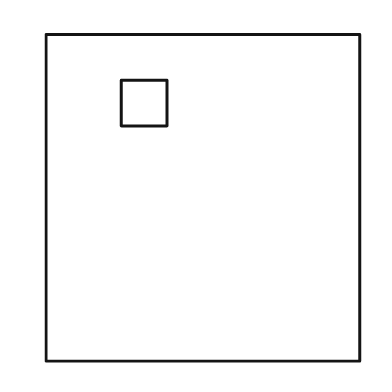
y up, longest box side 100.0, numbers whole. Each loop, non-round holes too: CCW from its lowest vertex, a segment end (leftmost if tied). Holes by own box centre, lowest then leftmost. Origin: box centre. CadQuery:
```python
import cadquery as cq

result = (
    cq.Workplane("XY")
    .moveTo(-48.0, -50.0)
    .lineTo(48.0, -50.0)
    .lineTo(48.0, 50.0)
    .lineTo(-48.0, 50.0)
    .close()
    .moveTo(-25.0, 22.0)
    .lineTo(-11.0, 22.0)
    .lineTo(-11.0, 36.0)
    .lineTo(-25.0, 36.0)
    .close()
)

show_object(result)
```